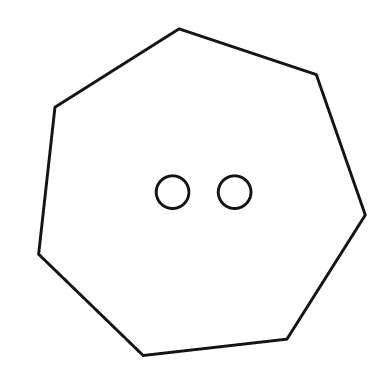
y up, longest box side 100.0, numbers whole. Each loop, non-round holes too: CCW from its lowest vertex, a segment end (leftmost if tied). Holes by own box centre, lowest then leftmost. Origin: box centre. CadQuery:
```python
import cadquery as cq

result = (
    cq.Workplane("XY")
    .moveTo(-18.0, -50.0)
    .lineTo(26.0, -45.0)
    .lineTo(50.0, -7.0)
    .lineTo(35.0, 36.0)
    .lineTo(-7.0, 50.0)
    .lineTo(-45.0, 26.0)
    .lineTo(-50.0, -19.0)
    .close()
    .moveTo(-9.0, 0.0)
    .circle(5.0)
    .moveTo(10.0, 0.0)
    .circle(5.0)
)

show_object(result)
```